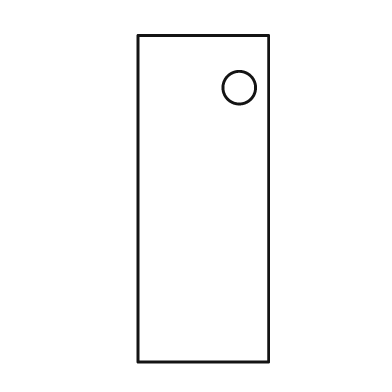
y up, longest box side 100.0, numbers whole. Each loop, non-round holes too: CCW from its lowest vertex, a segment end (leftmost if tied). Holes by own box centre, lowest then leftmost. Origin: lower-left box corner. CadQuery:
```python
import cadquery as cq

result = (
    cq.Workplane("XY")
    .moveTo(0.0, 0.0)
    .lineTo(40.0, 0.0)
    .lineTo(40.0, 100.0)
    .lineTo(0.0, 100.0)
    .close()
    .moveTo(31.0, 84.0)
    .circle(5.0)
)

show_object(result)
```